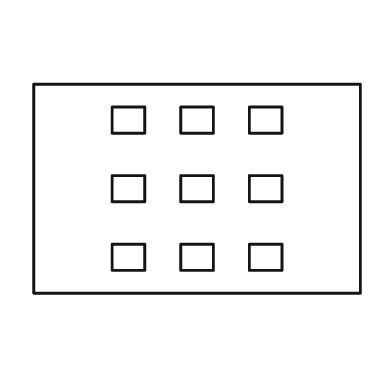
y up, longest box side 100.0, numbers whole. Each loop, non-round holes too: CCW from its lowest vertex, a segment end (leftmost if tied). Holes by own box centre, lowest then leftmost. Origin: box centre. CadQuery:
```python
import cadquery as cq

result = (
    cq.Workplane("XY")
    .moveTo(-50.0, -32.0)
    .lineTo(50.0, -32.0)
    .lineTo(50.0, 32.0)
    .lineTo(-50.0, 32.0)
    .close()
    .moveTo(-26.0, -25.0)
    .lineTo(-16.0, -25.0)
    .lineTo(-16.0, -17.0)
    .lineTo(-26.0, -17.0)
    .close()
    .moveTo(-5.0, -25.0)
    .lineTo(5.0, -25.0)
    .lineTo(5.0, -17.0)
    .lineTo(-5.0, -17.0)
    .close()
    .moveTo(16.0, -25.0)
    .lineTo(26.0, -25.0)
    .lineTo(26.0, -17.0)
    .lineTo(16.0, -17.0)
    .close()
    .moveTo(-26.0, -4.0)
    .lineTo(-16.0, -4.0)
    .lineTo(-16.0, 4.0)
    .lineTo(-26.0, 4.0)
    .close()
    .moveTo(-5.0, -4.0)
    .lineTo(5.0, -4.0)
    .lineTo(5.0, 4.0)
    .lineTo(-5.0, 4.0)
    .close()
    .moveTo(16.0, -4.0)
    .lineTo(26.0, -4.0)
    .lineTo(26.0, 4.0)
    .lineTo(16.0, 4.0)
    .close()
    .moveTo(-26.0, 17.0)
    .lineTo(-16.0, 17.0)
    .lineTo(-16.0, 25.0)
    .lineTo(-26.0, 25.0)
    .close()
    .moveTo(-5.0, 17.0)
    .lineTo(5.0, 17.0)
    .lineTo(5.0, 25.0)
    .lineTo(-5.0, 25.0)
    .close()
    .moveTo(16.0, 17.0)
    .lineTo(26.0, 17.0)
    .lineTo(26.0, 25.0)
    .lineTo(16.0, 25.0)
    .close()
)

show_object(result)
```